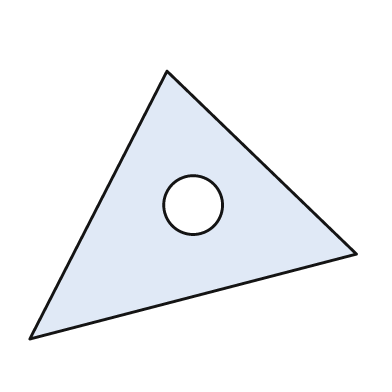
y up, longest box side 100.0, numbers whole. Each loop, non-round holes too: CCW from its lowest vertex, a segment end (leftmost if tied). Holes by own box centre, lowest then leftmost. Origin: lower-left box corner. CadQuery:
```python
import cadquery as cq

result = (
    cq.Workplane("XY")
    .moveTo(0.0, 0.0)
    .lineTo(100.0, 26.0)
    .lineTo(42.0, 82.0)
    .close()
    .moveTo(50.0, 41.0)
    .circle(9.0)
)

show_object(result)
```